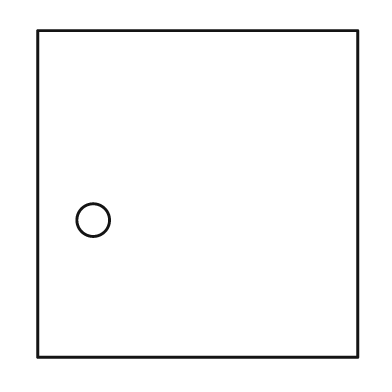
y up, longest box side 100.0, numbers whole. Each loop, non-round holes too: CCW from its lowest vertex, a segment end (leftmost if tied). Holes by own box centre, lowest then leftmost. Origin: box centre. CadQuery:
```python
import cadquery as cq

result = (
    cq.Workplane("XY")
    .moveTo(-49.0, -50.0)
    .lineTo(49.0, -50.0)
    .lineTo(49.0, 50.0)
    .lineTo(-49.0, 50.0)
    .close()
    .moveTo(-32.0, -8.0)
    .circle(5.0)
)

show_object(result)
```